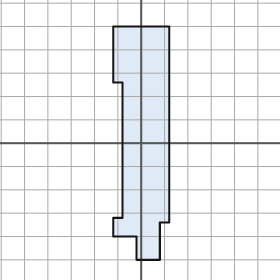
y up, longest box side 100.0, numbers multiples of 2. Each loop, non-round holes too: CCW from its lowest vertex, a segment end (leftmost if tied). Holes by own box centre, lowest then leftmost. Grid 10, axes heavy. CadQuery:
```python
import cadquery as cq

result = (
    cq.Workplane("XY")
    .moveTo(-2.0, -50.0)
    .lineTo(8.0, -50.0)
    .lineTo(8.0, -34.0)
    .lineTo(12.0, -34.0)
    .lineTo(12.0, 50.0)
    .lineTo(-12.0, 50.0)
    .lineTo(-12.0, 26.0)
    .lineTo(-8.0, 26.0)
    .lineTo(-8.0, -32.0)
    .lineTo(-12.0, -32.0)
    .lineTo(-12.0, -40.0)
    .lineTo(-2.0, -40.0)
    .close()
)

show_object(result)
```